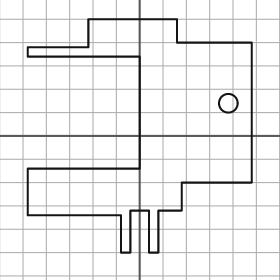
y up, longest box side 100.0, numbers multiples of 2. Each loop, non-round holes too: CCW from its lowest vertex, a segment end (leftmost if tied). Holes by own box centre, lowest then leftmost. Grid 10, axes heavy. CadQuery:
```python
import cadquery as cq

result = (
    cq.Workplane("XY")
    .moveTo(-8.0, -50.0)
    .lineTo(-4.0, -50.0)
    .lineTo(-4.0, -32.0)
    .lineTo(4.0, -32.0)
    .lineTo(4.0, -50.0)
    .lineTo(8.0, -50.0)
    .lineTo(8.0, -32.0)
    .lineTo(18.0, -32.0)
    .lineTo(18.0, -20.0)
    .lineTo(48.0, -20.0)
    .lineTo(48.0, 40.0)
    .lineTo(16.0, 40.0)
    .lineTo(16.0, 50.0)
    .lineTo(-22.0, 50.0)
    .lineTo(-22.0, 38.0)
    .lineTo(-48.0, 38.0)
    .lineTo(-48.0, 34.0)
    .lineTo(0.0, 34.0)
    .lineTo(0.0, -14.0)
    .lineTo(-48.0, -14.0)
    .lineTo(-48.0, -34.0)
    .lineTo(-8.0, -34.0)
    .close()
    .moveTo(38.0, 14.0)
    .circle(4.0)
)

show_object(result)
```